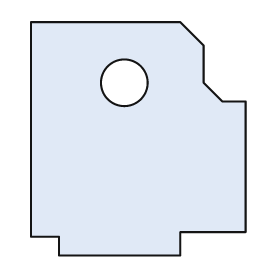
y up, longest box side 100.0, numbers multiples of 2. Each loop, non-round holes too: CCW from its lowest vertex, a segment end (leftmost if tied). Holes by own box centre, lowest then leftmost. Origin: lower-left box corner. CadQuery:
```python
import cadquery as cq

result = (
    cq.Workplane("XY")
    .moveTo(12.0, 0.0)
    .lineTo(64.0, 0.0)
    .lineTo(64.0, 10.0)
    .lineTo(92.0, 10.0)
    .lineTo(92.0, 66.0)
    .lineTo(82.0, 66.0)
    .lineTo(74.0, 74.0)
    .lineTo(74.0, 90.0)
    .lineTo(64.0, 100.0)
    .lineTo(0.0, 100.0)
    .lineTo(0.0, 8.0)
    .lineTo(12.0, 8.0)
    .close()
    .moveTo(40.0, 74.0)
    .circle(10.0)
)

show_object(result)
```